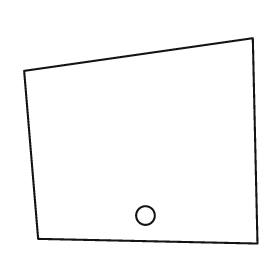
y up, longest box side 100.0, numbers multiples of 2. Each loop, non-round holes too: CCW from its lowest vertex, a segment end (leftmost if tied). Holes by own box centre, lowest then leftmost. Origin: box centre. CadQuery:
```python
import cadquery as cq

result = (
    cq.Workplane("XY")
    .moveTo(50.0, -44.0)
    .lineTo(48.0, 44.0)
    .lineTo(-50.0, 30.0)
    .lineTo(-44.0, -42.0)
    .close()
    .moveTo(2.0, -32.0)
    .circle(4.0)
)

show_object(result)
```